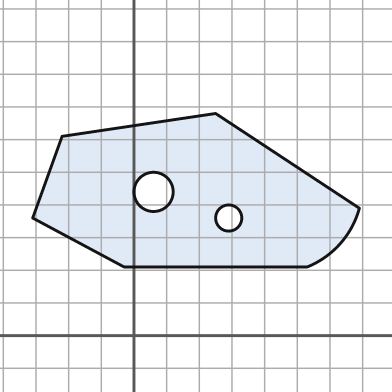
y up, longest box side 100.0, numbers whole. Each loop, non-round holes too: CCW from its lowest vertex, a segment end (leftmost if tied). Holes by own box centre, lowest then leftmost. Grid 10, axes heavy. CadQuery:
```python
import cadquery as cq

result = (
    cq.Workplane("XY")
    .moveTo(-3.0, 21.0)
    .lineTo(53.0, 21.0)
    .threePointArc((63.0, 28.0), (69.0, 39.0))
    .lineTo(25.0, 68.0)
    .lineTo(-22.0, 61.0)
    .lineTo(-31.0, 36.0)
    .close()
    .moveTo(29.0, 36.0)
    .circle(4.0)
    .moveTo(6.0, 44.0)
    .circle(6.0)
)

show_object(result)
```